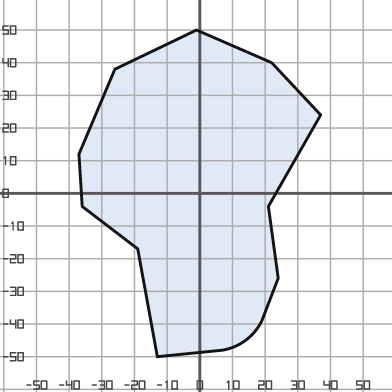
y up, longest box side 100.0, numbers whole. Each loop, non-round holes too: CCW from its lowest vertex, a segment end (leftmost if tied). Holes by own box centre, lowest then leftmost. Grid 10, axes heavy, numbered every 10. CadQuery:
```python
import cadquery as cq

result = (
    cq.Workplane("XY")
    .moveTo(-13.0, -50.0)
    .lineTo(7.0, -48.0)
    .threePointArc((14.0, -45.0), (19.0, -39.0))
    .lineTo(24.0, -26.0)
    .lineTo(21.0, -4.0)
    .lineTo(37.0, 24.0)
    .lineTo(22.0, 40.0)
    .lineTo(-1.0, 50.0)
    .lineTo(-26.0, 38.0)
    .lineTo(-37.0, 12.0)
    .lineTo(-36.0, -4.0)
    .lineTo(-19.0, -17.0)
    .close()
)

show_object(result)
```